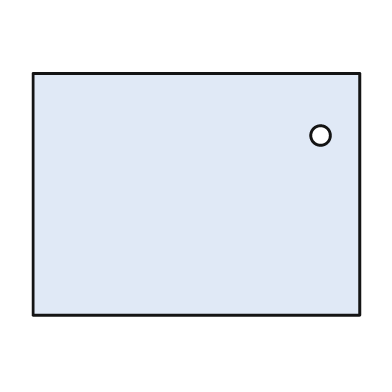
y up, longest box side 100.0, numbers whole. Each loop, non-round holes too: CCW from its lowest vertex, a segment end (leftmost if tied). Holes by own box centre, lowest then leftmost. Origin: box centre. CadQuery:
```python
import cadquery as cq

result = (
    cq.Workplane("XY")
    .moveTo(-50.0, -37.0)
    .lineTo(50.0, -37.0)
    .lineTo(50.0, 37.0)
    .lineTo(-50.0, 37.0)
    .close()
    .moveTo(38.0, 18.0)
    .circle(3.0)
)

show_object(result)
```